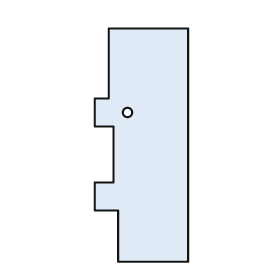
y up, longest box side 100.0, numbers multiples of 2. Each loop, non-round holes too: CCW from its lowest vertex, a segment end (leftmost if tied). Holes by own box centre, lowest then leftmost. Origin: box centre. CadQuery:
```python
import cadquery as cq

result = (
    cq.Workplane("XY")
    .moveTo(-10.0, -50.0)
    .lineTo(20.0, -50.0)
    .lineTo(20.0, 50.0)
    .lineTo(-14.0, 50.0)
    .lineTo(-14.0, 20.0)
    .lineTo(-20.0, 20.0)
    .lineTo(-20.0, 8.0)
    .lineTo(-12.0, 8.0)
    .lineTo(-12.0, -16.0)
    .lineTo(-20.0, -16.0)
    .lineTo(-20.0, -28.0)
    .lineTo(-10.0, -28.0)
    .close()
    .moveTo(-6.0, 14.0)
    .circle(2.0)
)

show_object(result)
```